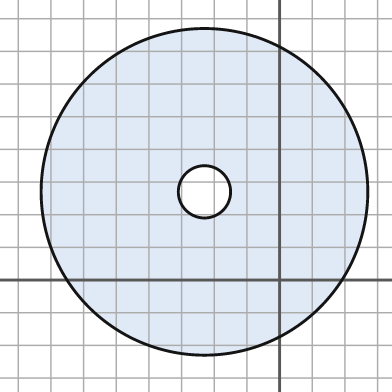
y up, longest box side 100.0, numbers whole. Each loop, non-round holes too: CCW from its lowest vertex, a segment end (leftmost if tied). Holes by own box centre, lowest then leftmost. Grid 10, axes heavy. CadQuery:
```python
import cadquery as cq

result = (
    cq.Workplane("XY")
    .moveTo(-23.0, 27.0)
    .circle(50.0)
    .moveTo(-23.0, 27.0)
    .circle(8.0)
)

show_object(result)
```